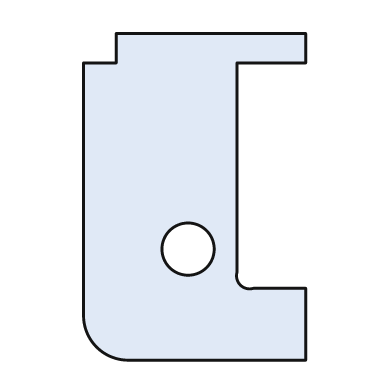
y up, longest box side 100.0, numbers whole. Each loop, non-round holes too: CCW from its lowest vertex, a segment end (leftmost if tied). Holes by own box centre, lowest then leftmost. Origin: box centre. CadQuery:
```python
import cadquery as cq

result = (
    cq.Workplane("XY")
    .moveTo(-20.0, -50.0)
    .lineTo(34.0, -50.0)
    .lineTo(34.0, -28.0)
    .lineTo(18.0, -28.0)
    .threePointArc((14.0, -27.0), (13.0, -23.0))
    .lineTo(13.0, 41.0)
    .lineTo(34.0, 41.0)
    .lineTo(34.0, 50.0)
    .lineTo(-24.0, 50.0)
    .lineTo(-24.0, 41.0)
    .lineTo(-34.0, 41.0)
    .lineTo(-34.0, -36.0)
    .threePointArc((-30.0, -46.0), (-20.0, -50.0))
    .close()
    .moveTo(-2.0, -16.0)
    .circle(8.0)
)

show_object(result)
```